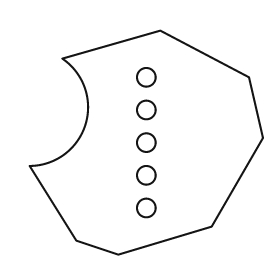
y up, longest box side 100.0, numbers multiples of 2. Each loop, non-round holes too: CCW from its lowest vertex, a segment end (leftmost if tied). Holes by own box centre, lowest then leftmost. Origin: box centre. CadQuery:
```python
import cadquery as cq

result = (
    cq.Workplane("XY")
    .moveTo(-12.0, -48.0)
    .lineTo(28.0, -36.0)
    .lineTo(50.0, 2.0)
    .lineTo(44.0, 28.0)
    .lineTo(6.0, 48.0)
    .lineTo(-36.0, 36.0)
    .threePointArc((-26.0, 8.0), (-50.0, -10.0))
    .lineTo(-30.0, -42.0)
    .close()
    .moveTo(0.0, -28.0)
    .circle(4.0)
    .moveTo(0.0, -14.0)
    .circle(4.0)
    .moveTo(0.0, 0.0)
    .circle(4.0)
    .moveTo(0.0, 14.0)
    .circle(4.0)
    .moveTo(0.0, 28.0)
    .circle(4.0)
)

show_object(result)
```